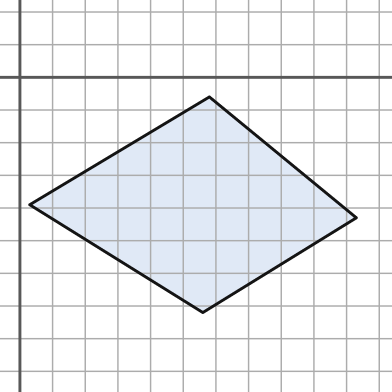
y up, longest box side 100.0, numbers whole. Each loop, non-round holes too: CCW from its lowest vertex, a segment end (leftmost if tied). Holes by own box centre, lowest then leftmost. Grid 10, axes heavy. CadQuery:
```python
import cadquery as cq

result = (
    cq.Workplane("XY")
    .moveTo(56.0, -72.0)
    .lineTo(103.0, -43.0)
    .lineTo(58.0, -6.0)
    .lineTo(3.0, -39.0)
    .close()
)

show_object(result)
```